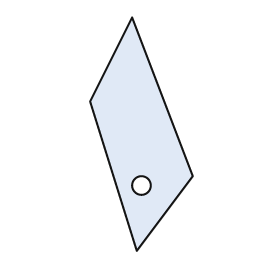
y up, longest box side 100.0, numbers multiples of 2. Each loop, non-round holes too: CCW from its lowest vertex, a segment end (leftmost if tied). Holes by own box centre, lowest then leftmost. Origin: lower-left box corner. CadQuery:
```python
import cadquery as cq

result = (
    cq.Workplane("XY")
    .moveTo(20.0, 0.0)
    .lineTo(44.0, 32.0)
    .lineTo(18.0, 100.0)
    .lineTo(0.0, 64.0)
    .close()
    .moveTo(22.0, 28.0)
    .circle(4.0)
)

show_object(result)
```